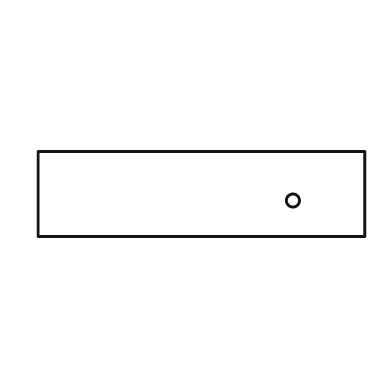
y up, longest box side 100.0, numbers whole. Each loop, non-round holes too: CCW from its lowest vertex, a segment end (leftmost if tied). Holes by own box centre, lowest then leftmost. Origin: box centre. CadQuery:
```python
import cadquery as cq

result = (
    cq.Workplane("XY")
    .moveTo(-50.0, -13.0)
    .lineTo(50.0, -13.0)
    .lineTo(50.0, 13.0)
    .lineTo(-50.0, 13.0)
    .close()
    .moveTo(28.0, -2.0)
    .circle(2.0)
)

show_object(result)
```